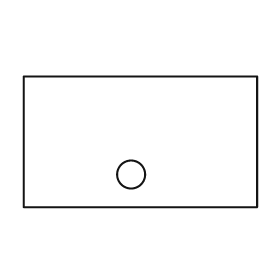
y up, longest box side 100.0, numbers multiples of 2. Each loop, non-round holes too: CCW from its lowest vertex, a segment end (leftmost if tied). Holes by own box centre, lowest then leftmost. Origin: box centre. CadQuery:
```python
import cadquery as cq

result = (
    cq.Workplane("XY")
    .moveTo(-50.0, -28.0)
    .lineTo(50.0, -28.0)
    .lineTo(50.0, 28.0)
    .lineTo(-50.0, 28.0)
    .close()
    .moveTo(-4.0, -14.0)
    .circle(6.0)
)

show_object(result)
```